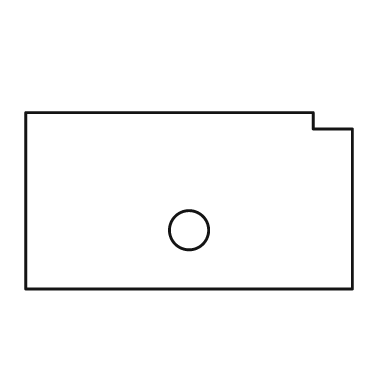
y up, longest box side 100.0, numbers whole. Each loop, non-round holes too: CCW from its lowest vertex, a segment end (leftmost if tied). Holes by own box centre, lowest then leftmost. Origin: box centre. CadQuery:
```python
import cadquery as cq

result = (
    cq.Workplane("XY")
    .moveTo(-50.0, -27.0)
    .lineTo(50.0, -27.0)
    .lineTo(50.0, 22.0)
    .lineTo(38.0, 22.0)
    .lineTo(38.0, 27.0)
    .lineTo(-50.0, 27.0)
    .close()
    .moveTo(0.0, -9.0)
    .circle(6.0)
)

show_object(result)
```